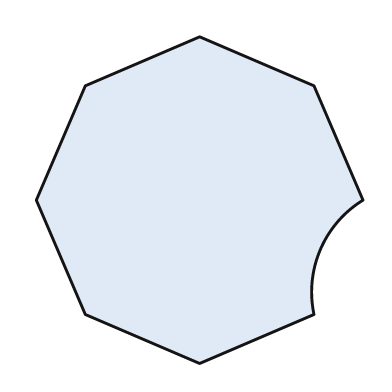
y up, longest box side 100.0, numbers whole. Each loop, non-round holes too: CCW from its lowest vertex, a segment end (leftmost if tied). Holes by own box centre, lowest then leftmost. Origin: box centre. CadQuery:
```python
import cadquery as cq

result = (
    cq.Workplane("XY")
    .moveTo(0.0, -50.0)
    .lineTo(35.0, -35.0)
    .threePointArc((37.0, -15.0), (50.0, 0.0))
    .lineTo(35.0, 35.0)
    .lineTo(0.0, 50.0)
    .lineTo(-35.0, 35.0)
    .lineTo(-50.0, 0.0)
    .lineTo(-35.0, -35.0)
    .close()
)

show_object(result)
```